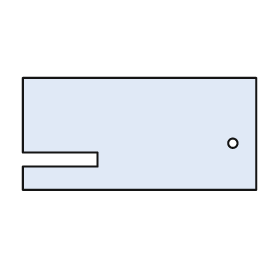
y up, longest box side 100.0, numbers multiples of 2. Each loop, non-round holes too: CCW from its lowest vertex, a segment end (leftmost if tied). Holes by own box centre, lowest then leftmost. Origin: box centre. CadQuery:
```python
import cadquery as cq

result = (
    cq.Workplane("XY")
    .moveTo(-50.0, -24.0)
    .lineTo(50.0, -24.0)
    .lineTo(50.0, 24.0)
    .lineTo(-50.0, 24.0)
    .lineTo(-50.0, -8.0)
    .lineTo(-18.0, -8.0)
    .lineTo(-18.0, -14.0)
    .lineTo(-50.0, -14.0)
    .close()
    .moveTo(40.0, -4.0)
    .circle(2.0)
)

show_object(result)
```